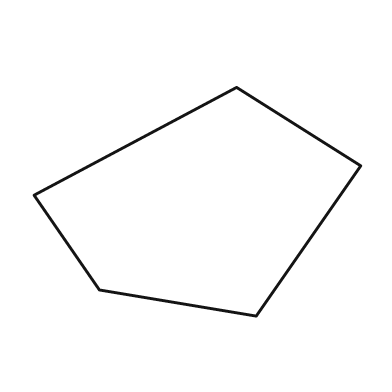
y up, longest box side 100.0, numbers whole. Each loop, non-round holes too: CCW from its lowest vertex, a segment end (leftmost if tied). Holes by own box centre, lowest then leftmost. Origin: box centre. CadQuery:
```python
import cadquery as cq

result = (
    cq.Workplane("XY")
    .moveTo(18.0, -35.0)
    .lineTo(50.0, 11.0)
    .lineTo(12.0, 35.0)
    .lineTo(-50.0, 2.0)
    .lineTo(-30.0, -27.0)
    .close()
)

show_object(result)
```